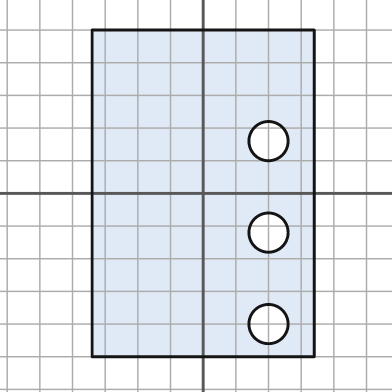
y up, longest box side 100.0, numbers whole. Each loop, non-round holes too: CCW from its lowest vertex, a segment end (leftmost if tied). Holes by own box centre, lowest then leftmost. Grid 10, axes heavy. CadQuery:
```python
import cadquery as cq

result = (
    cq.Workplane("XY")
    .moveTo(-34.0, -50.0)
    .lineTo(34.0, -50.0)
    .lineTo(34.0, 50.0)
    .lineTo(-34.0, 50.0)
    .close()
    .moveTo(20.0, -40.0)
    .circle(6.0)
    .moveTo(20.0, -12.0)
    .circle(6.0)
    .moveTo(20.0, 16.0)
    .circle(6.0)
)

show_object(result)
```